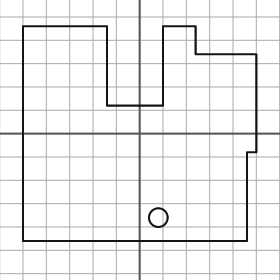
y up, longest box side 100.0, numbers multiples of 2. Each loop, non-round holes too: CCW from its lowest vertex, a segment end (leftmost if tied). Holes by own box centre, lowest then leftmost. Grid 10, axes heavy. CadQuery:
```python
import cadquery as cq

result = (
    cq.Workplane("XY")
    .moveTo(-50.0, -46.0)
    .lineTo(46.0, -46.0)
    .lineTo(46.0, -8.0)
    .lineTo(50.0, -8.0)
    .lineTo(50.0, 34.0)
    .lineTo(24.0, 34.0)
    .lineTo(24.0, 46.0)
    .lineTo(10.0, 46.0)
    .lineTo(10.0, 12.0)
    .lineTo(-14.0, 12.0)
    .lineTo(-14.0, 46.0)
    .lineTo(-50.0, 46.0)
    .close()
    .moveTo(8.0, -36.0)
    .circle(4.0)
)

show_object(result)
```